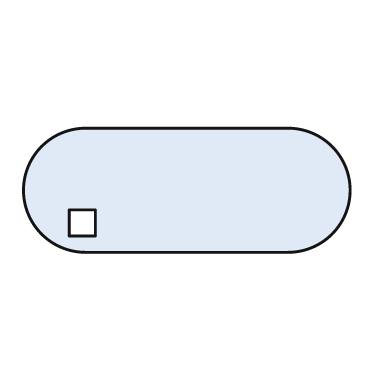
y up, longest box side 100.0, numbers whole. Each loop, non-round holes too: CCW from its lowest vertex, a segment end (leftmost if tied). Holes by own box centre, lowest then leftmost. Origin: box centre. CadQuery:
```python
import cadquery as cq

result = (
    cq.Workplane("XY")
    .moveTo(-31.0, -19.0)
    .lineTo(31.0, -19.0)
    .threePointArc((50.0, 0.0), (31.0, 19.0))
    .lineTo(-31.0, 19.0)
    .threePointArc((-50.0, 0.0), (-31.0, -19.0))
    .close()
    .moveTo(-36.0, -14.0)
    .lineTo(-28.0, -14.0)
    .lineTo(-28.0, -6.0)
    .lineTo(-36.0, -6.0)
    .close()
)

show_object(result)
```